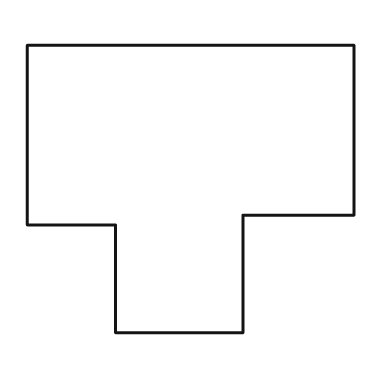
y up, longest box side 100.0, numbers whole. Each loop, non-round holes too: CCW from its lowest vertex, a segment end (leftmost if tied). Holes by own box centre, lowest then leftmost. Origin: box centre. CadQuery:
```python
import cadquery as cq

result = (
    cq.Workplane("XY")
    .moveTo(-23.0, -44.0)
    .lineTo(16.0, -44.0)
    .lineTo(16.0, -8.0)
    .lineTo(50.0, -8.0)
    .lineTo(50.0, 44.0)
    .lineTo(-50.0, 44.0)
    .lineTo(-50.0, -11.0)
    .lineTo(-23.0, -11.0)
    .close()
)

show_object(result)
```